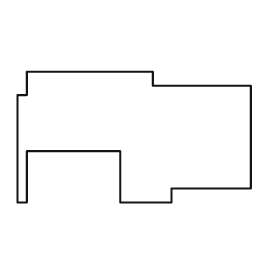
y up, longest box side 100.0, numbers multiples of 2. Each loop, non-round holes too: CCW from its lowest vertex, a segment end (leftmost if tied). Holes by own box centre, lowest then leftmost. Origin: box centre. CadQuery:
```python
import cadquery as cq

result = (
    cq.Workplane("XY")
    .moveTo(-50.0, -28.0)
    .lineTo(-46.0, -28.0)
    .lineTo(-46.0, -6.0)
    .lineTo(-6.0, -6.0)
    .lineTo(-6.0, -28.0)
    .lineTo(16.0, -28.0)
    .lineTo(16.0, -22.0)
    .lineTo(50.0, -22.0)
    .lineTo(50.0, 22.0)
    .lineTo(8.0, 22.0)
    .lineTo(8.0, 28.0)
    .lineTo(-46.0, 28.0)
    .lineTo(-46.0, 18.0)
    .lineTo(-50.0, 18.0)
    .close()
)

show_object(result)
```